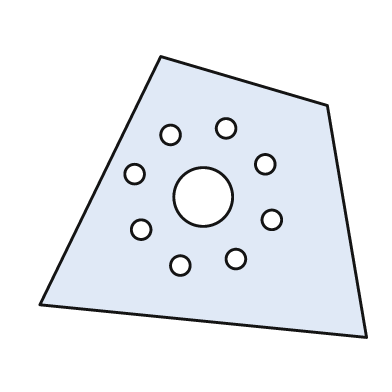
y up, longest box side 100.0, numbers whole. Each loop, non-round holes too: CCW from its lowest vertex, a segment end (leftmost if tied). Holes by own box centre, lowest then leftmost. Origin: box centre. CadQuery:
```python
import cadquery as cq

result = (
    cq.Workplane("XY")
    .moveTo(50.0, -43.0)
    .lineTo(38.0, 28.0)
    .lineTo(-13.0, 43.0)
    .lineTo(-50.0, -33.0)
    .close()
    .moveTo(-7.0, -21.0)
    .circle(3.0)
    .moveTo(10.0, -19.0)
    .circle(3.0)
    .moveTo(-19.0, -10.0)
    .circle(3.0)
    .moveTo(21.0, -7.0)
    .circle(3.0)
    .moveTo(0.0, 0.0)
    .circle(9.0)
    .moveTo(-21.0, 7.0)
    .circle(3.0)
    .moveTo(19.0, 10.0)
    .circle(3.0)
    .moveTo(-10.0, 19.0)
    .circle(3.0)
    .moveTo(7.0, 21.0)
    .circle(3.0)
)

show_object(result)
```